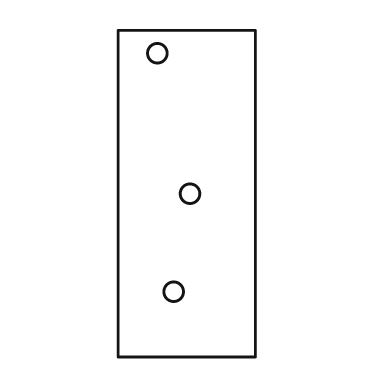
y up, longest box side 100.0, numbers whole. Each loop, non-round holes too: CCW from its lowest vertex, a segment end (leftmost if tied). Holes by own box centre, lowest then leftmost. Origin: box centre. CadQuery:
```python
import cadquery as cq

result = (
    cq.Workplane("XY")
    .moveTo(-21.0, -50.0)
    .lineTo(21.0, -50.0)
    .lineTo(21.0, 50.0)
    .lineTo(-21.0, 50.0)
    .close()
    .moveTo(-4.0, -30.0)
    .circle(3.0)
    .moveTo(1.0, 0.0)
    .circle(3.0)
    .moveTo(-9.0, 43.0)
    .circle(3.0)
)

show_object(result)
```